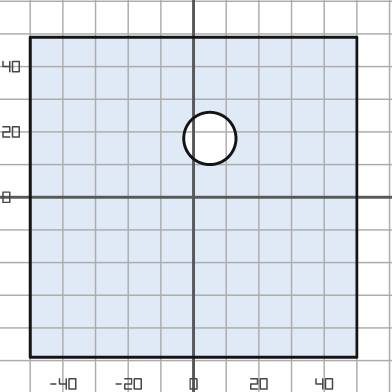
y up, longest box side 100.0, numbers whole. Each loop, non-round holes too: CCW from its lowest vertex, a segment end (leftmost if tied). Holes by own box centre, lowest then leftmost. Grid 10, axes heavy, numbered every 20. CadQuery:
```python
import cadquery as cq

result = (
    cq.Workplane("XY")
    .moveTo(-50.0, -49.0)
    .lineTo(50.0, -49.0)
    .lineTo(50.0, 49.0)
    .lineTo(-50.0, 49.0)
    .close()
    .moveTo(5.0, 18.0)
    .circle(8.0)
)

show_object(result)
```